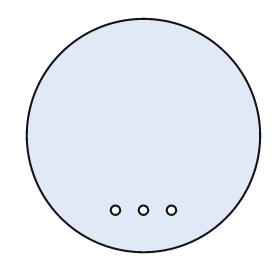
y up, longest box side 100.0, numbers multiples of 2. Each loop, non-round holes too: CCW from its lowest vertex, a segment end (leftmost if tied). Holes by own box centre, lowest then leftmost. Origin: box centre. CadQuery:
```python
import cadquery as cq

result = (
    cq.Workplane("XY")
    .moveTo(0.0, 0.0)
    .circle(50.0)
    .moveTo(-12.0, -32.0)
    .circle(2.0)
    .moveTo(0.0, -32.0)
    .circle(2.0)
    .moveTo(12.0, -32.0)
    .circle(2.0)
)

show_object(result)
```